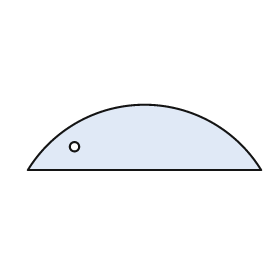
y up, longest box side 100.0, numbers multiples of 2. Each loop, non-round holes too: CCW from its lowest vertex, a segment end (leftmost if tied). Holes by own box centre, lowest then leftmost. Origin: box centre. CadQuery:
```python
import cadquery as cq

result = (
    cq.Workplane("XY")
    .moveTo(-50.0, -14.0)
    .lineTo(50.0, -14.0)
    .threePointArc((0.0, 14.0), (-50.0, -14.0))
    .close()
    .moveTo(-30.0, -4.0)
    .circle(2.0)
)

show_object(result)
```